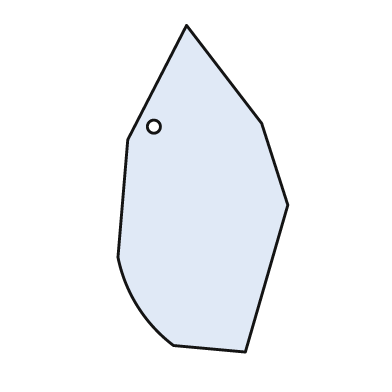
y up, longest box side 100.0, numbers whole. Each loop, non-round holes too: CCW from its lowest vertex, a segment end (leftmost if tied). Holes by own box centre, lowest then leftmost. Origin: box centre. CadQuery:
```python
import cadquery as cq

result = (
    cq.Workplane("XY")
    .moveTo(13.0, -50.0)
    .lineTo(26.0, -5.0)
    .lineTo(18.0, 20.0)
    .lineTo(-5.0, 50.0)
    .lineTo(-23.0, 15.0)
    .lineTo(-26.0, -21.0)
    .threePointArc((-20.0, -36.0), (-9.0, -48.0))
    .close()
    .moveTo(-15.0, 19.0)
    .circle(2.0)
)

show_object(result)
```